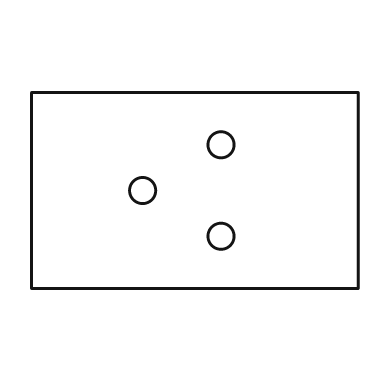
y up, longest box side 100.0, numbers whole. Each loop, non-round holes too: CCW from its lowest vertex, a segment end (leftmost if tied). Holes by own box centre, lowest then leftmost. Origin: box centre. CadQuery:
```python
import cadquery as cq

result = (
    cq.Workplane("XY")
    .moveTo(-50.0, -30.0)
    .lineTo(50.0, -30.0)
    .lineTo(50.0, 30.0)
    .lineTo(-50.0, 30.0)
    .close()
    .moveTo(8.0, -14.0)
    .circle(4.0)
    .moveTo(-16.0, 0.0)
    .circle(4.0)
    .moveTo(8.0, 14.0)
    .circle(4.0)
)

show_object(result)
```